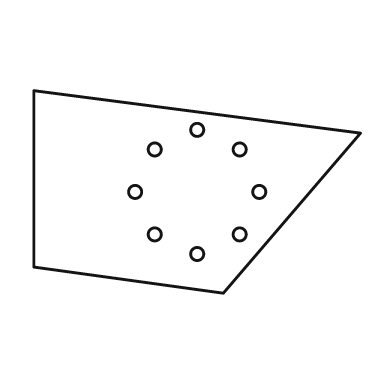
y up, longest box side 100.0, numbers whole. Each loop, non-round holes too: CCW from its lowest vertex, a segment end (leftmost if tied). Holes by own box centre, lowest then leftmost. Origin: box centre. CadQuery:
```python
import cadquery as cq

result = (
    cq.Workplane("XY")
    .moveTo(8.0, -31.0)
    .lineTo(50.0, 18.0)
    .lineTo(-50.0, 31.0)
    .lineTo(-50.0, -23.0)
    .close()
    .moveTo(0.0, -19.0)
    .circle(2.0)
    .moveTo(-13.0, -13.0)
    .circle(2.0)
    .moveTo(13.0, -13.0)
    .circle(2.0)
    .moveTo(-19.0, 0.0)
    .circle(2.0)
    .moveTo(19.0, 0.0)
    .circle(2.0)
    .moveTo(-13.0, 13.0)
    .circle(2.0)
    .moveTo(13.0, 13.0)
    .circle(2.0)
    .moveTo(0.0, 19.0)
    .circle(2.0)
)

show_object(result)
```